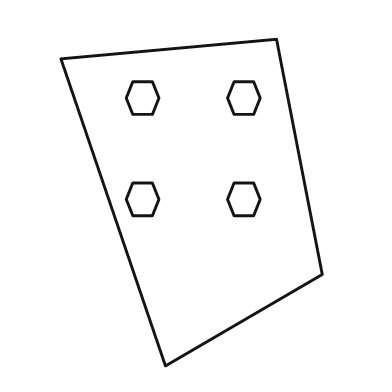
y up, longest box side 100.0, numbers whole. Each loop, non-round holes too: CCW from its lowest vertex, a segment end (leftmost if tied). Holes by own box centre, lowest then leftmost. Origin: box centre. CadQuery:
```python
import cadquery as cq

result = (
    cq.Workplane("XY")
    .moveTo(-8.0, -50.0)
    .lineTo(40.0, -22.0)
    .lineTo(26.0, 50.0)
    .lineTo(-40.0, 44.0)
    .close()
    .moveTo(-18.0, -4.0)
    .lineTo(-12.0, -4.0)
    .lineTo(-10.0, 1.0)
    .lineTo(-12.0, 6.0)
    .lineTo(-18.0, 6.0)
    .lineTo(-20.0, 1.0)
    .close()
    .moveTo(13.0, -4.0)
    .lineTo(19.0, -4.0)
    .lineTo(21.0, 1.0)
    .lineTo(19.0, 6.0)
    .lineTo(13.0, 6.0)
    .lineTo(11.0, 1.0)
    .close()
    .moveTo(-18.0, 27.0)
    .lineTo(-12.0, 27.0)
    .lineTo(-10.0, 32.0)
    .lineTo(-12.0, 37.0)
    .lineTo(-18.0, 37.0)
    .lineTo(-20.0, 32.0)
    .close()
    .moveTo(13.0, 27.0)
    .lineTo(19.0, 27.0)
    .lineTo(21.0, 32.0)
    .lineTo(19.0, 37.0)
    .lineTo(13.0, 37.0)
    .lineTo(11.0, 32.0)
    .close()
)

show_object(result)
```